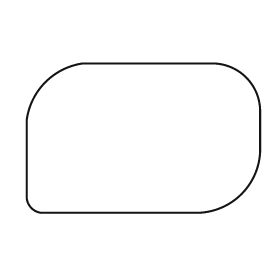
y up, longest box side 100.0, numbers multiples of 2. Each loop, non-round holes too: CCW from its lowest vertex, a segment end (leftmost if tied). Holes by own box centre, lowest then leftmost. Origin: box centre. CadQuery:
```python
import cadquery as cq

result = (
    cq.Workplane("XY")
    .moveTo(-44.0, -32.0)
    .lineTo(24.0, -32.0)
    .threePointArc((42.0, -24.0), (50.0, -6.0))
    .lineTo(50.0, 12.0)
    .threePointArc((44.0, 26.0), (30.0, 32.0))
    .lineTo(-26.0, 32.0)
    .threePointArc((-42.0, 24.0), (-50.0, 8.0))
    .lineTo(-50.0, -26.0)
    .threePointArc((-48.0, -30.0), (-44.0, -32.0))
    .close()
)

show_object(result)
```